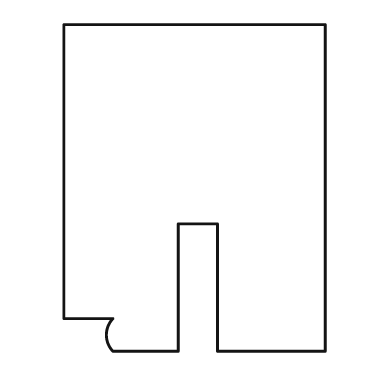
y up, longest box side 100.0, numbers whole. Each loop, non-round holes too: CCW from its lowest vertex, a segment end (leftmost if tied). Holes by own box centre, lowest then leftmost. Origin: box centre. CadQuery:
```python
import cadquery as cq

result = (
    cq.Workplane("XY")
    .moveTo(-25.0, -50.0)
    .lineTo(-5.0, -50.0)
    .lineTo(-5.0, -11.0)
    .lineTo(7.0, -11.0)
    .lineTo(7.0, -50.0)
    .lineTo(40.0, -50.0)
    .lineTo(40.0, 50.0)
    .lineTo(-40.0, 50.0)
    .lineTo(-40.0, -40.0)
    .lineTo(-25.0, -40.0)
    .threePointArc((-27.0, -45.0), (-25.0, -50.0))
    .close()
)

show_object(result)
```